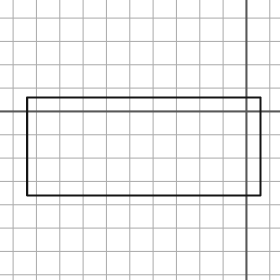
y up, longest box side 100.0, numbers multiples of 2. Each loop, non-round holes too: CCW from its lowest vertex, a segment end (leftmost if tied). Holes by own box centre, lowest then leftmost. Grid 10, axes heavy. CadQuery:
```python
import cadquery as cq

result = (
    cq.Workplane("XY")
    .moveTo(-94.0, -36.0)
    .lineTo(6.0, -36.0)
    .lineTo(6.0, 6.0)
    .lineTo(-94.0, 6.0)
    .close()
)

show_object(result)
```